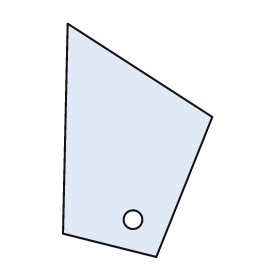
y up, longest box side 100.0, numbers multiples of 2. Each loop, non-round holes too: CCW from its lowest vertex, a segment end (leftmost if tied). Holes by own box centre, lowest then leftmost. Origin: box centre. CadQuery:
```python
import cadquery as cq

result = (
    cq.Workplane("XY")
    .moveTo(8.0, -50.0)
    .lineTo(32.0, 10.0)
    .lineTo(-30.0, 50.0)
    .lineTo(-32.0, -40.0)
    .close()
    .moveTo(-2.0, -34.0)
    .circle(4.0)
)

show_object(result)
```